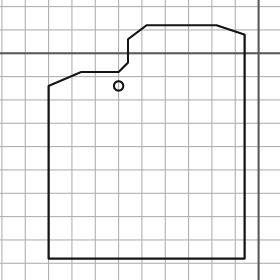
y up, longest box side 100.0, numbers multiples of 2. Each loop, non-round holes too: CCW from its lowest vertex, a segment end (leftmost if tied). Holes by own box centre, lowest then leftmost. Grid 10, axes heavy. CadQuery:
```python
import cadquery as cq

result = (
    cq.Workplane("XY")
    .moveTo(-90.0, -88.0)
    .lineTo(-6.0, -88.0)
    .lineTo(-6.0, 8.0)
    .lineTo(-18.0, 12.0)
    .lineTo(-48.0, 12.0)
    .lineTo(-56.0, 6.0)
    .lineTo(-56.0, -4.0)
    .lineTo(-60.0, -8.0)
    .lineTo(-76.0, -8.0)
    .lineTo(-90.0, -14.0)
    .close()
    .moveTo(-60.0, -14.0)
    .circle(2.0)
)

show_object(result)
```